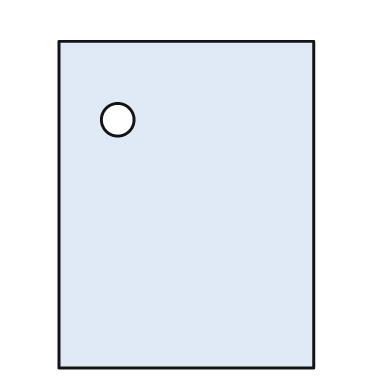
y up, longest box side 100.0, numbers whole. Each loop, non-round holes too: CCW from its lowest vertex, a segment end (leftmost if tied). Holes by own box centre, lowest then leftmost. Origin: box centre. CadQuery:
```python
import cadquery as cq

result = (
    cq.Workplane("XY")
    .moveTo(-39.0, -50.0)
    .lineTo(39.0, -50.0)
    .lineTo(39.0, 50.0)
    .lineTo(-39.0, 50.0)
    .close()
    .moveTo(-21.0, 26.0)
    .circle(5.0)
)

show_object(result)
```